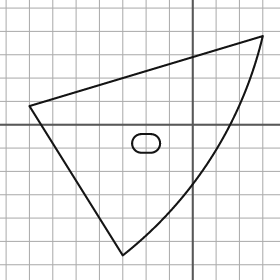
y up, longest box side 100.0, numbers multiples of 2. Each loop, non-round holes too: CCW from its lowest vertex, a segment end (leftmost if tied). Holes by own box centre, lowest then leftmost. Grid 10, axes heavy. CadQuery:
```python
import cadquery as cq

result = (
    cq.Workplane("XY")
    .moveTo(-30.0, -56.0)
    .threePointArc((8.0, -14.0), (30.0, 38.0))
    .lineTo(-70.0, 8.0)
    .close()
    .moveTo(-22.0, -12.0)
    .lineTo(-18.0, -12.0)
    .threePointArc((-14.0, -8.0), (-18.0, -4.0))
    .lineTo(-22.0, -4.0)
    .threePointArc((-26.0, -8.0), (-22.0, -12.0))
    .close()
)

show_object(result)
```